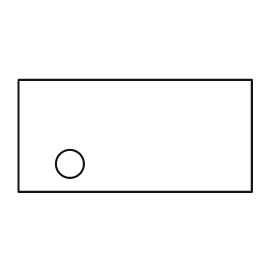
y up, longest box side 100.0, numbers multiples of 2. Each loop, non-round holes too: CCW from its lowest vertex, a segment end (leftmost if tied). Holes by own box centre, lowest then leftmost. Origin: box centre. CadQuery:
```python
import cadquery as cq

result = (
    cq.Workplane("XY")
    .moveTo(-50.0, -24.0)
    .lineTo(50.0, -24.0)
    .lineTo(50.0, 24.0)
    .lineTo(-50.0, 24.0)
    .close()
    .moveTo(-28.0, -12.0)
    .circle(6.0)
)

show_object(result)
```